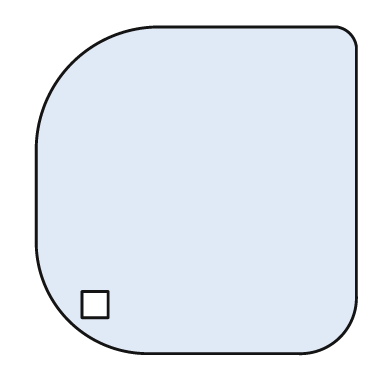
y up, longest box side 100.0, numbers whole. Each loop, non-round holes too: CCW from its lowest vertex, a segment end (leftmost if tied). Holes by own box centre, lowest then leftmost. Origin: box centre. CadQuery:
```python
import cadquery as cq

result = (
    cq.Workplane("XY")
    .moveTo(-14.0, -50.0)
    .lineTo(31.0, -50.0)
    .threePointArc((44.0, -45.0), (49.0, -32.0))
    .lineTo(49.0, 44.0)
    .threePointArc((47.0, 48.0), (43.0, 50.0))
    .lineTo(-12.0, 50.0)
    .threePointArc((-38.0, 39.0), (-49.0, 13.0))
    .lineTo(-49.0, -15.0)
    .threePointArc((-39.0, -40.0), (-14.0, -50.0))
    .close()
    .moveTo(-35.0, -39.0)
    .lineTo(-27.0, -39.0)
    .lineTo(-27.0, -31.0)
    .lineTo(-35.0, -31.0)
    .close()
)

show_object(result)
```